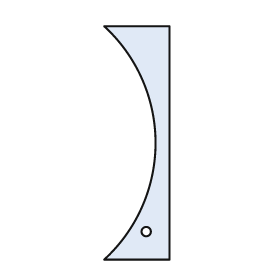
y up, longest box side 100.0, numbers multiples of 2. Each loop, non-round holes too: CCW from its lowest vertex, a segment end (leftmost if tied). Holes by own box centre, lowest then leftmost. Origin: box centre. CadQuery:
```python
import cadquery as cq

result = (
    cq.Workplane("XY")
    .moveTo(-14.0, -50.0)
    .lineTo(14.0, -50.0)
    .lineTo(14.0, 50.0)
    .lineTo(-14.0, 50.0)
    .threePointArc((8.0, 0.0), (-14.0, -50.0))
    .close()
    .moveTo(4.0, -38.0)
    .circle(2.0)
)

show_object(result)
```